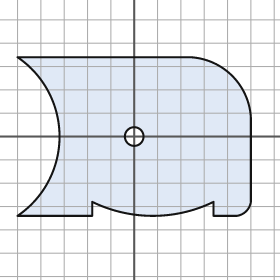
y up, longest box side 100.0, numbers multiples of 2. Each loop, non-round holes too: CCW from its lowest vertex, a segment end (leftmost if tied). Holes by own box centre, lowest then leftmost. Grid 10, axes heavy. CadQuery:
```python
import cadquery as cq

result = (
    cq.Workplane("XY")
    .moveTo(-50.0, -34.0)
    .lineTo(-18.0, -34.0)
    .lineTo(-18.0, -28.0)
    .threePointArc((8.0, -34.0), (34.0, -28.0))
    .lineTo(34.0, -34.0)
    .lineTo(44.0, -34.0)
    .threePointArc((48.0, -32.0), (50.0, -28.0))
    .lineTo(50.0, 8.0)
    .threePointArc((42.0, 26.0), (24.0, 34.0))
    .lineTo(-50.0, 34.0)
    .threePointArc((-32.0, 0.0), (-50.0, -34.0))
    .close()
    .moveTo(0.0, 0.0)
    .circle(4.0)
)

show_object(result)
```